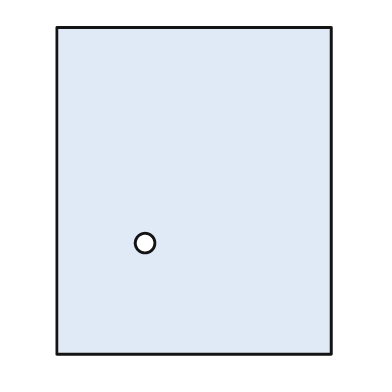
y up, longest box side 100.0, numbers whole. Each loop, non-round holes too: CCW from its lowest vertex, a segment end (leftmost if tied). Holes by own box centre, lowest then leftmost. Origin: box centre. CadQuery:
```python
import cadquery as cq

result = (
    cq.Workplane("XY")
    .moveTo(-42.0, -50.0)
    .lineTo(42.0, -50.0)
    .lineTo(42.0, 50.0)
    .lineTo(-42.0, 50.0)
    .close()
    .moveTo(-15.0, -16.0)
    .circle(3.0)
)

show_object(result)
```